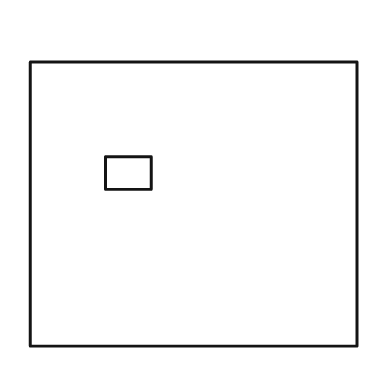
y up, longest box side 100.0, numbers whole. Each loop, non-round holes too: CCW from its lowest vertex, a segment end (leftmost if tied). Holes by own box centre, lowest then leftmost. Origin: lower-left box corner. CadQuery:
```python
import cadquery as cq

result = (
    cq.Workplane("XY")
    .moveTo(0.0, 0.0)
    .lineTo(100.0, 0.0)
    .lineTo(100.0, 87.0)
    .lineTo(0.0, 87.0)
    .close()
    .moveTo(23.0, 48.0)
    .lineTo(37.0, 48.0)
    .lineTo(37.0, 58.0)
    .lineTo(23.0, 58.0)
    .close()
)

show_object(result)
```